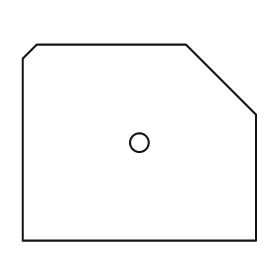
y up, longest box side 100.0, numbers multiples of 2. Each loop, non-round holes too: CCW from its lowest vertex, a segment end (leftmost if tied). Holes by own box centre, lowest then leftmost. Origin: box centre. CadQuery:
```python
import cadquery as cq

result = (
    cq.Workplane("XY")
    .moveTo(-50.0, -42.0)
    .lineTo(50.0, -42.0)
    .lineTo(50.0, 12.0)
    .lineTo(20.0, 42.0)
    .lineTo(-44.0, 42.0)
    .lineTo(-50.0, 36.0)
    .close()
    .moveTo(0.0, 0.0)
    .circle(4.0)
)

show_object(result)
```